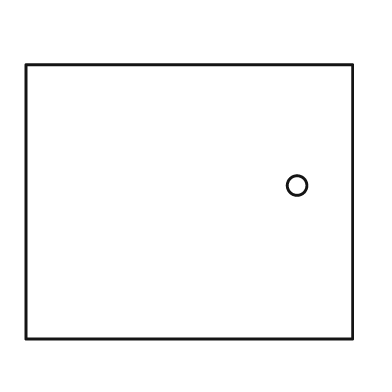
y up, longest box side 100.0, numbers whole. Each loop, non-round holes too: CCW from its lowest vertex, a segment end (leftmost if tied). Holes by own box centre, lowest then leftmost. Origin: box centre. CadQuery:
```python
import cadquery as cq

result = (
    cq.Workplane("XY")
    .moveTo(-50.0, -42.0)
    .lineTo(50.0, -42.0)
    .lineTo(50.0, 42.0)
    .lineTo(-50.0, 42.0)
    .close()
    .moveTo(33.0, 5.0)
    .circle(3.0)
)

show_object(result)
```